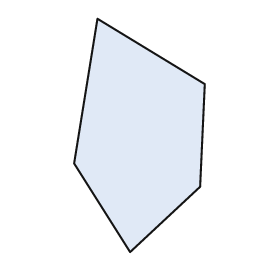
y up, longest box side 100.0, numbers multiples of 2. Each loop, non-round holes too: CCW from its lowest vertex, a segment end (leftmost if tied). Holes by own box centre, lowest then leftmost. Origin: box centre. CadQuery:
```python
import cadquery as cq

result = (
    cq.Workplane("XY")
    .moveTo(-4.0, -50.0)
    .lineTo(26.0, -22.0)
    .lineTo(28.0, 22.0)
    .lineTo(-18.0, 50.0)
    .lineTo(-28.0, -12.0)
    .close()
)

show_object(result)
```